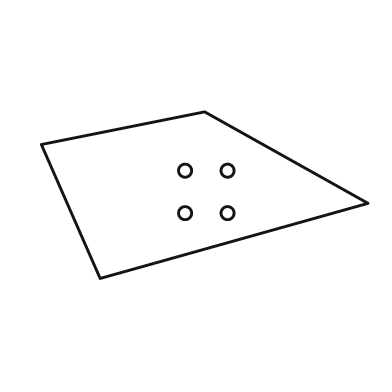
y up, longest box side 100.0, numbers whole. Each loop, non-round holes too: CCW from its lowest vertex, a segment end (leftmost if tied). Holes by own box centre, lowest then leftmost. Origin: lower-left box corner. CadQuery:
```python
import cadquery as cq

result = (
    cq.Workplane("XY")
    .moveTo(18.0, 0.0)
    .lineTo(100.0, 23.0)
    .lineTo(50.0, 51.0)
    .lineTo(0.0, 41.0)
    .close()
    .moveTo(44.0, 20.0)
    .circle(2.0)
    .moveTo(57.0, 20.0)
    .circle(2.0)
    .moveTo(44.0, 33.0)
    .circle(2.0)
    .moveTo(57.0, 33.0)
    .circle(2.0)
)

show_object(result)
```